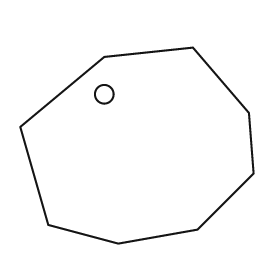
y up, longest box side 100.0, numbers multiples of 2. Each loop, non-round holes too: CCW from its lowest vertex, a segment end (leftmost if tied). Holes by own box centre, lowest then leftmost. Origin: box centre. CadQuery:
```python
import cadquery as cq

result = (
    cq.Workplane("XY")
    .moveTo(-8.0, -42.0)
    .lineTo(26.0, -36.0)
    .lineTo(50.0, -12.0)
    .lineTo(48.0, 14.0)
    .lineTo(24.0, 42.0)
    .lineTo(-14.0, 38.0)
    .lineTo(-50.0, 8.0)
    .lineTo(-38.0, -34.0)
    .close()
    .moveTo(-14.0, 22.0)
    .circle(4.0)
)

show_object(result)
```